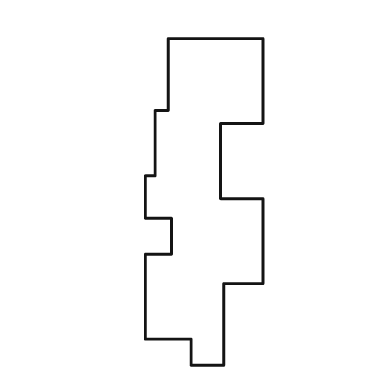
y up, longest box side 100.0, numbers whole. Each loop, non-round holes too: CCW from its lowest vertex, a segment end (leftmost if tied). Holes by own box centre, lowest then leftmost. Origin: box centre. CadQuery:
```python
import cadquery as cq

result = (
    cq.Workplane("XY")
    .moveTo(-4.0, -50.0)
    .lineTo(6.0, -50.0)
    .lineTo(6.0, -25.0)
    .lineTo(18.0, -25.0)
    .lineTo(18.0, 1.0)
    .lineTo(5.0, 1.0)
    .lineTo(5.0, 24.0)
    .lineTo(18.0, 24.0)
    .lineTo(18.0, 50.0)
    .lineTo(-11.0, 50.0)
    .lineTo(-11.0, 28.0)
    .lineTo(-15.0, 28.0)
    .lineTo(-15.0, 8.0)
    .lineTo(-18.0, 8.0)
    .lineTo(-18.0, -5.0)
    .lineTo(-10.0, -5.0)
    .lineTo(-10.0, -16.0)
    .lineTo(-18.0, -16.0)
    .lineTo(-18.0, -42.0)
    .lineTo(-4.0, -42.0)
    .close()
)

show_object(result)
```